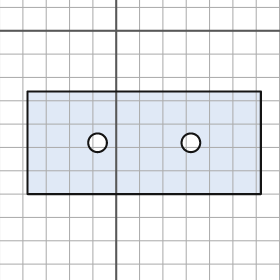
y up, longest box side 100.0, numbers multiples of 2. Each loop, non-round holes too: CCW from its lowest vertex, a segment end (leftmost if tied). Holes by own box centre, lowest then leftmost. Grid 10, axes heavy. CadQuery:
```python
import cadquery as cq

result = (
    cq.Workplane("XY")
    .moveTo(-38.0, -70.0)
    .lineTo(62.0, -70.0)
    .lineTo(62.0, -26.0)
    .lineTo(-38.0, -26.0)
    .close()
    .moveTo(-8.0, -48.0)
    .circle(4.0)
    .moveTo(32.0, -48.0)
    .circle(4.0)
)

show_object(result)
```